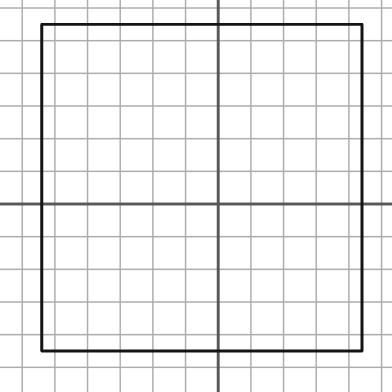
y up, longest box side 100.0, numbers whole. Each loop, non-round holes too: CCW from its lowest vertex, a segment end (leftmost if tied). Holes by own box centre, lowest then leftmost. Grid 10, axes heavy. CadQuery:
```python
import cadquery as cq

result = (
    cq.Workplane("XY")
    .moveTo(-54.0, -45.0)
    .lineTo(44.0, -45.0)
    .lineTo(44.0, 55.0)
    .lineTo(-54.0, 55.0)
    .close()
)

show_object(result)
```